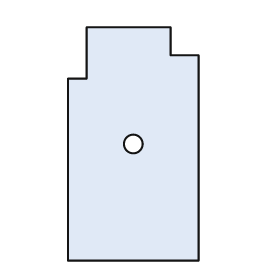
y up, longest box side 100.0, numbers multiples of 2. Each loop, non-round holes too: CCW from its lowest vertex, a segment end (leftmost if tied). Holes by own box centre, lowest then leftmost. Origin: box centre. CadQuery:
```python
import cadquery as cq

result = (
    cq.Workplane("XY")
    .moveTo(-28.0, -50.0)
    .lineTo(28.0, -50.0)
    .lineTo(28.0, 38.0)
    .lineTo(16.0, 38.0)
    .lineTo(16.0, 50.0)
    .lineTo(-20.0, 50.0)
    .lineTo(-20.0, 28.0)
    .lineTo(-28.0, 28.0)
    .close()
    .moveTo(0.0, 0.0)
    .circle(4.0)
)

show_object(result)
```